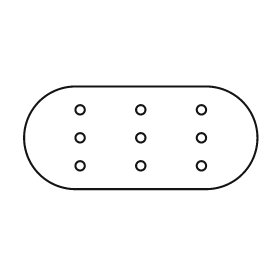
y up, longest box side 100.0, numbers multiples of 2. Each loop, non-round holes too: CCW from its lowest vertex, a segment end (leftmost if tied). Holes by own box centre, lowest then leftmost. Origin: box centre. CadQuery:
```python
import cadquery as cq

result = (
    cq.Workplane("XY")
    .moveTo(-28.0, -22.0)
    .lineTo(28.0, -22.0)
    .threePointArc((50.0, 0.0), (28.0, 22.0))
    .lineTo(-28.0, 22.0)
    .threePointArc((-50.0, 0.0), (-28.0, -22.0))
    .close()
    .moveTo(-26.0, -12.0)
    .circle(2.0)
    .moveTo(0.0, -12.0)
    .circle(2.0)
    .moveTo(26.0, -12.0)
    .circle(2.0)
    .moveTo(-26.0, 0.0)
    .circle(2.0)
    .moveTo(0.0, 0.0)
    .circle(2.0)
    .moveTo(26.0, 0.0)
    .circle(2.0)
    .moveTo(-26.0, 12.0)
    .circle(2.0)
    .moveTo(0.0, 12.0)
    .circle(2.0)
    .moveTo(26.0, 12.0)
    .circle(2.0)
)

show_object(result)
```